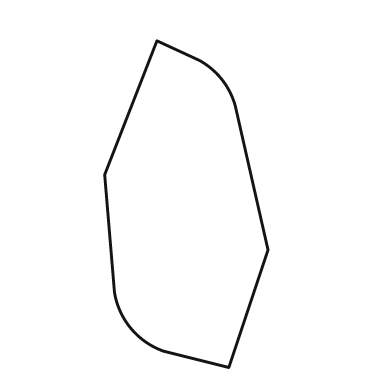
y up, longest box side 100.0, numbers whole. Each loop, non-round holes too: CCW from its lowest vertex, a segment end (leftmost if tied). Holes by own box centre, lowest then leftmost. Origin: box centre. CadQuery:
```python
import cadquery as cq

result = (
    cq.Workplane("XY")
    .moveTo(13.0, -50.0)
    .lineTo(25.0, -14.0)
    .lineTo(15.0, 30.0)
    .threePointArc((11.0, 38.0), (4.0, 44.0))
    .lineTo(-9.0, 50.0)
    .lineTo(-25.0, 9.0)
    .lineTo(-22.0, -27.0)
    .threePointArc((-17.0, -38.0), (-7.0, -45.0))
    .close()
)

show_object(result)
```